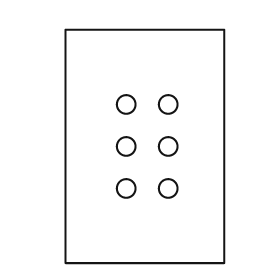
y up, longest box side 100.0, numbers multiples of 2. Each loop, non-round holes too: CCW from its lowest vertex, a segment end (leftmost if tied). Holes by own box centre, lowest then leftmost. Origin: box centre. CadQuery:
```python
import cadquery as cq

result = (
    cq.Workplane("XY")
    .moveTo(-34.0, -50.0)
    .lineTo(34.0, -50.0)
    .lineTo(34.0, 50.0)
    .lineTo(-34.0, 50.0)
    .close()
    .moveTo(-8.0, -18.0)
    .circle(4.0)
    .moveTo(10.0, -18.0)
    .circle(4.0)
    .moveTo(-8.0, 0.0)
    .circle(4.0)
    .moveTo(10.0, 0.0)
    .circle(4.0)
    .moveTo(-8.0, 18.0)
    .circle(4.0)
    .moveTo(10.0, 18.0)
    .circle(4.0)
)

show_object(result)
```